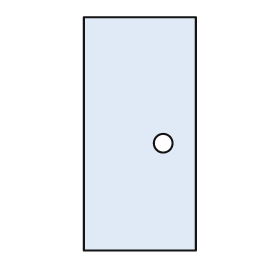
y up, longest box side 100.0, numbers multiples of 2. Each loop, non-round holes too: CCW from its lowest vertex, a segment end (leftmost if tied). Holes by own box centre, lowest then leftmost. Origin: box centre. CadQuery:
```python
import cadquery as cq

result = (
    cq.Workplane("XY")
    .moveTo(-24.0, -50.0)
    .lineTo(24.0, -50.0)
    .lineTo(24.0, 50.0)
    .lineTo(-24.0, 50.0)
    .close()
    .moveTo(10.0, -4.0)
    .circle(4.0)
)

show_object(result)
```